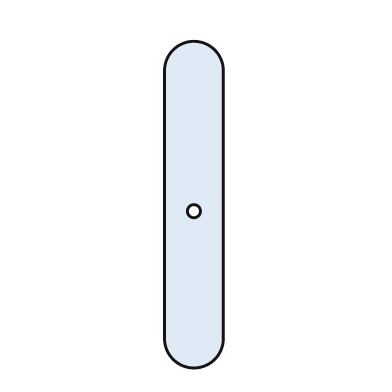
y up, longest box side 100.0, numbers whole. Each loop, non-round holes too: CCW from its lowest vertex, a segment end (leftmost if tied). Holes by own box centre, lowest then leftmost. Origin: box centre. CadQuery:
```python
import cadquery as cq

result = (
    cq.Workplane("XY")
    .moveTo(-9.0, -41.0)
    .threePointArc((0.0, -50.0), (9.0, -41.0))
    .lineTo(9.0, 41.0)
    .threePointArc((0.0, 50.0), (-9.0, 41.0))
    .close()
    .moveTo(0.0, -2.0)
    .circle(2.0)
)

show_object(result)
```